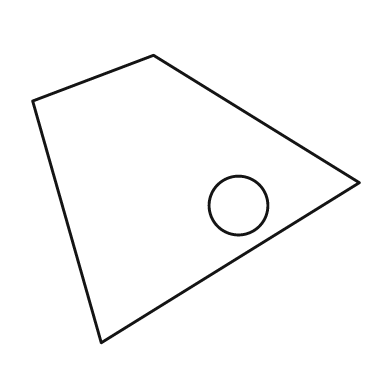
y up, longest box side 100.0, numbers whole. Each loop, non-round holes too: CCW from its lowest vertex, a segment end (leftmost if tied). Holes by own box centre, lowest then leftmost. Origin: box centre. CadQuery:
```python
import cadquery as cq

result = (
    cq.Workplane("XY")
    .moveTo(-29.0, -44.0)
    .lineTo(50.0, 5.0)
    .lineTo(-13.0, 44.0)
    .lineTo(-50.0, 30.0)
    .close()
    .moveTo(13.0, -2.0)
    .circle(9.0)
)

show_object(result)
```